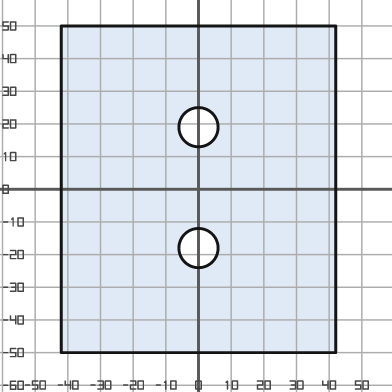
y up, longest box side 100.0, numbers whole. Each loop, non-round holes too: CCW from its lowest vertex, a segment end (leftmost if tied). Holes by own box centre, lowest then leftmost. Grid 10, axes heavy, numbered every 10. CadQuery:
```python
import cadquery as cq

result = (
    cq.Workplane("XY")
    .moveTo(-42.0, -50.0)
    .lineTo(42.0, -50.0)
    .lineTo(42.0, 50.0)
    .lineTo(-42.0, 50.0)
    .close()
    .moveTo(0.0, -18.0)
    .circle(6.0)
    .moveTo(0.0, 19.0)
    .circle(6.0)
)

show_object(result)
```